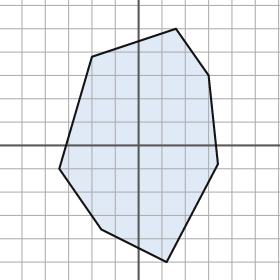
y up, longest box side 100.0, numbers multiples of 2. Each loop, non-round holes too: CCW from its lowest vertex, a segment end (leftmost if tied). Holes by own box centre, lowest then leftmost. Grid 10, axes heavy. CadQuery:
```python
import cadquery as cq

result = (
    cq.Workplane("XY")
    .moveTo(12.0, -50.0)
    .lineTo(34.0, -8.0)
    .lineTo(30.0, 30.0)
    .lineTo(16.0, 50.0)
    .lineTo(-20.0, 38.0)
    .lineTo(-34.0, -10.0)
    .lineTo(-16.0, -36.0)
    .close()
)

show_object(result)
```